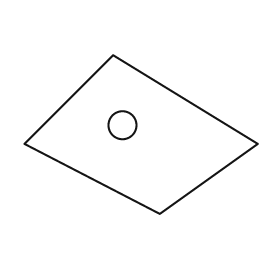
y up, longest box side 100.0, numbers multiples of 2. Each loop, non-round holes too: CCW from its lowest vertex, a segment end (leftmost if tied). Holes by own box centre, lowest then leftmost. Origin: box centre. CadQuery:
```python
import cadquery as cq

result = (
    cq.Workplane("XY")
    .moveTo(8.0, -34.0)
    .lineTo(50.0, -4.0)
    .lineTo(-12.0, 34.0)
    .lineTo(-50.0, -4.0)
    .close()
    .moveTo(-8.0, 4.0)
    .circle(6.0)
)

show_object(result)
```